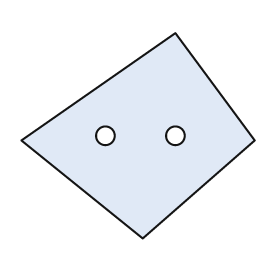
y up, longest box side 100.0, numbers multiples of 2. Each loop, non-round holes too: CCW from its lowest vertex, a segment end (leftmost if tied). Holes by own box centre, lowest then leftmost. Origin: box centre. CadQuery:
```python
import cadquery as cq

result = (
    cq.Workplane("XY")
    .moveTo(2.0, -44.0)
    .lineTo(50.0, -2.0)
    .lineTo(16.0, 44.0)
    .lineTo(-50.0, -2.0)
    .close()
    .moveTo(-14.0, 0.0)
    .circle(4.0)
    .moveTo(16.0, 0.0)
    .circle(4.0)
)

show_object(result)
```